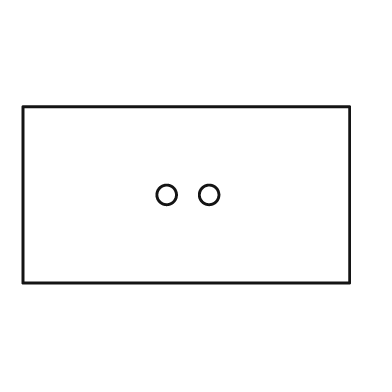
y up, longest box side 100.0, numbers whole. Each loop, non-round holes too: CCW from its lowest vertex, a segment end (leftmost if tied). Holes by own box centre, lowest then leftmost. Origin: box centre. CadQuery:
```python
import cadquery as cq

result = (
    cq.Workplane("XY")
    .moveTo(-50.0, -27.0)
    .lineTo(50.0, -27.0)
    .lineTo(50.0, 27.0)
    .lineTo(-50.0, 27.0)
    .close()
    .moveTo(-6.0, 0.0)
    .circle(3.0)
    .moveTo(7.0, 0.0)
    .circle(3.0)
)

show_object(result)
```